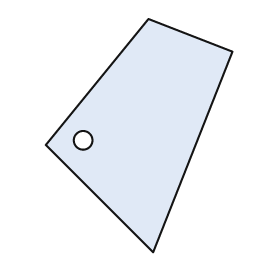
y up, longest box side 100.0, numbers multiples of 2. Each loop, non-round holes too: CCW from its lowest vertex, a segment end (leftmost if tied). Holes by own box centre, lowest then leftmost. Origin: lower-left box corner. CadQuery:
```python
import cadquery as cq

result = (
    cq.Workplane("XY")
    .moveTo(46.0, 0.0)
    .lineTo(80.0, 86.0)
    .lineTo(44.0, 100.0)
    .lineTo(0.0, 46.0)
    .close()
    .moveTo(16.0, 48.0)
    .circle(4.0)
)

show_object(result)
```